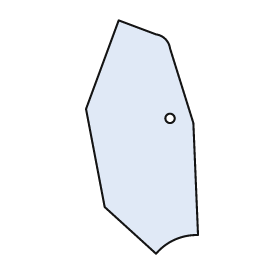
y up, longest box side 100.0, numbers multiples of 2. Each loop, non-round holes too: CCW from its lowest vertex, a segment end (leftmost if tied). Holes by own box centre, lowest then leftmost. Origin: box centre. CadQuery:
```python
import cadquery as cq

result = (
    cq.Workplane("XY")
    .moveTo(6.0, -50.0)
    .threePointArc((14.0, -44.0), (24.0, -42.0))
    .lineTo(22.0, 6.0)
    .lineTo(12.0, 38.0)
    .threePointArc((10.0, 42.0), (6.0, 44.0))
    .lineTo(-10.0, 50.0)
    .lineTo(-24.0, 12.0)
    .lineTo(-16.0, -30.0)
    .close()
    .moveTo(12.0, 8.0)
    .circle(2.0)
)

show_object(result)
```